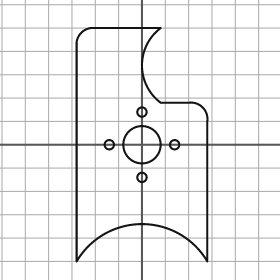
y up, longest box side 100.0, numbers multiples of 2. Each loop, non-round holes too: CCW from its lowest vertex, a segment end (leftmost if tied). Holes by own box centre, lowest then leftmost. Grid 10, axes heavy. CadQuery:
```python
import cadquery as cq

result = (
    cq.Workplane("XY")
    .moveTo(-28.0, -50.0)
    .threePointArc((0.0, -34.0), (28.0, -50.0))
    .lineTo(28.0, 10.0)
    .threePointArc((26.0, 16.0), (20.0, 18.0))
    .lineTo(8.0, 18.0)
    .threePointArc((0.0, 34.0), (8.0, 50.0))
    .lineTo(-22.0, 50.0)
    .threePointArc((-26.0, 48.0), (-28.0, 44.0))
    .close()
    .moveTo(0.0, -14.0)
    .circle(2.0)
    .moveTo(-14.0, 0.0)
    .circle(2.0)
    .moveTo(0.0, 0.0)
    .circle(8.0)
    .moveTo(14.0, 0.0)
    .circle(2.0)
    .moveTo(0.0, 14.0)
    .circle(2.0)
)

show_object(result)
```